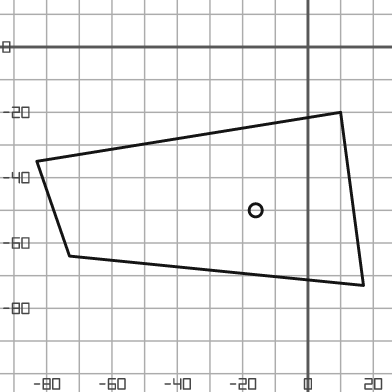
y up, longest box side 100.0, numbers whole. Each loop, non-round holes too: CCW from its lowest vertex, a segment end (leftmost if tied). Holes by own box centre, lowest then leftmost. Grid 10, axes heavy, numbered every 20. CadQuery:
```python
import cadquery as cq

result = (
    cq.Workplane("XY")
    .moveTo(17.0, -73.0)
    .lineTo(10.0, -20.0)
    .lineTo(-83.0, -35.0)
    .lineTo(-73.0, -64.0)
    .close()
    .moveTo(-16.0, -50.0)
    .circle(2.0)
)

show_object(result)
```